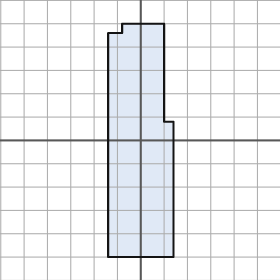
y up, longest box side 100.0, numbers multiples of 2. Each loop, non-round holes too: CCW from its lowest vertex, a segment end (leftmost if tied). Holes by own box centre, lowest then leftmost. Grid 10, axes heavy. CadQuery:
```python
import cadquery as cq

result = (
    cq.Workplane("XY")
    .moveTo(-14.0, -50.0)
    .lineTo(14.0, -50.0)
    .lineTo(14.0, 8.0)
    .lineTo(10.0, 8.0)
    .lineTo(10.0, 50.0)
    .lineTo(-8.0, 50.0)
    .lineTo(-8.0, 46.0)
    .lineTo(-14.0, 46.0)
    .close()
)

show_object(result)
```